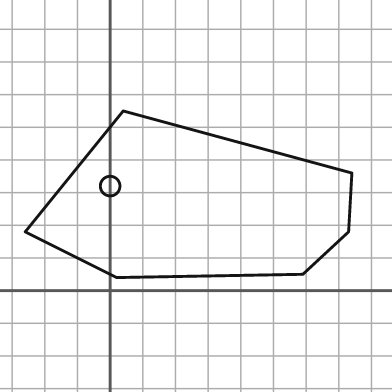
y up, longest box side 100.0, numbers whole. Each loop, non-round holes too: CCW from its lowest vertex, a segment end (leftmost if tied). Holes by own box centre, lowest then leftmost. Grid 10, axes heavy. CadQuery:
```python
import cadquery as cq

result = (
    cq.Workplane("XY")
    .moveTo(2.0, 4.0)
    .lineTo(59.0, 5.0)
    .lineTo(73.0, 18.0)
    .lineTo(74.0, 36.0)
    .lineTo(4.0, 55.0)
    .lineTo(-26.0, 18.0)
    .close()
    .moveTo(0.0, 32.0)
    .circle(3.0)
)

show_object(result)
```